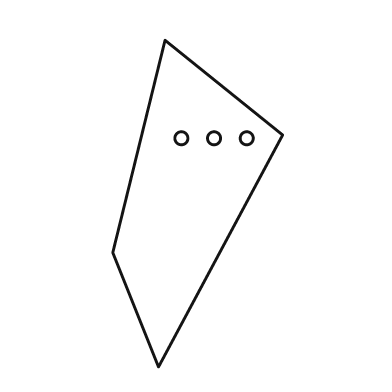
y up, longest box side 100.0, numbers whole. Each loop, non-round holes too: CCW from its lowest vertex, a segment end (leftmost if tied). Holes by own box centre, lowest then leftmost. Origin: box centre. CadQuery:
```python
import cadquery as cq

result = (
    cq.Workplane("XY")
    .moveTo(-12.0, -50.0)
    .lineTo(26.0, 21.0)
    .lineTo(-10.0, 50.0)
    .lineTo(-26.0, -15.0)
    .close()
    .moveTo(-5.0, 20.0)
    .circle(2.0)
    .moveTo(5.0, 20.0)
    .circle(2.0)
    .moveTo(15.0, 20.0)
    .circle(2.0)
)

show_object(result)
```